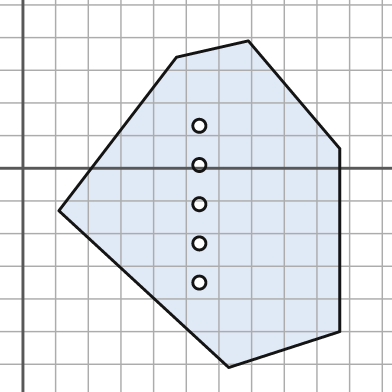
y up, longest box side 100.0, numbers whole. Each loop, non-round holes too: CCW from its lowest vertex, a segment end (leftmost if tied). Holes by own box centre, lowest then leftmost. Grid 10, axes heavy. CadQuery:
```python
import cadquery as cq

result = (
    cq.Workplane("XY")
    .moveTo(63.0, -61.0)
    .lineTo(97.0, -50.0)
    .lineTo(97.0, 6.0)
    .lineTo(69.0, 39.0)
    .lineTo(47.0, 34.0)
    .lineTo(11.0, -13.0)
    .close()
    .moveTo(54.0, -35.0)
    .circle(2.0)
    .moveTo(54.0, -23.0)
    .circle(2.0)
    .moveTo(54.0, -11.0)
    .circle(2.0)
    .moveTo(54.0, 1.0)
    .circle(2.0)
    .moveTo(54.0, 13.0)
    .circle(2.0)
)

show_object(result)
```